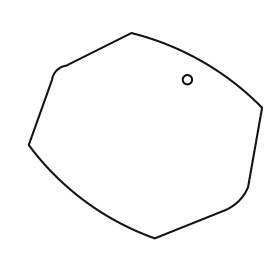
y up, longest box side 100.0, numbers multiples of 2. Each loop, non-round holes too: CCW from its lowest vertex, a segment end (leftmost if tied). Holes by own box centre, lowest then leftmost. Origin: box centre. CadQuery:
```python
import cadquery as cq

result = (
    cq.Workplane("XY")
    .moveTo(4.0, -44.0)
    .lineTo(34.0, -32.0)
    .threePointArc((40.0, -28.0), (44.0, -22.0))
    .lineTo(50.0, 12.0)
    .threePointArc((24.0, 32.0), (-6.0, 44.0))
    .lineTo(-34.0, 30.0)
    .threePointArc((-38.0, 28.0), (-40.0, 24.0))
    .lineTo(-50.0, -4.0)
    .threePointArc((-26.0, -28.0), (4.0, -44.0))
    .close()
    .moveTo(18.0, 24.0)
    .circle(2.0)
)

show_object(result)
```